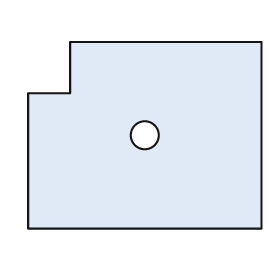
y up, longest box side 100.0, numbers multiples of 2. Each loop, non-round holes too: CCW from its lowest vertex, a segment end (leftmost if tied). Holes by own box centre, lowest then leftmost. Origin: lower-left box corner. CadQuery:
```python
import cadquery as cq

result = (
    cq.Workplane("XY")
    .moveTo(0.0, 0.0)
    .lineTo(100.0, 0.0)
    .lineTo(100.0, 80.0)
    .lineTo(18.0, 80.0)
    .lineTo(18.0, 58.0)
    .lineTo(0.0, 58.0)
    .close()
    .moveTo(50.0, 40.0)
    .circle(6.0)
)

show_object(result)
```